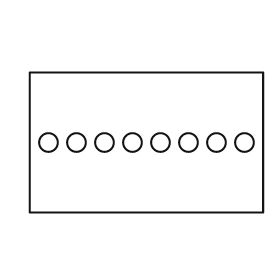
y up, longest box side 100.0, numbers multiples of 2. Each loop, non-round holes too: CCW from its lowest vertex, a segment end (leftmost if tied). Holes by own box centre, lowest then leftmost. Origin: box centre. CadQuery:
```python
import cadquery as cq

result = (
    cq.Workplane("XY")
    .moveTo(-50.0, -30.0)
    .lineTo(50.0, -30.0)
    .lineTo(50.0, 30.0)
    .lineTo(-50.0, 30.0)
    .close()
    .moveTo(-42.0, 0.0)
    .circle(4.0)
    .moveTo(-30.0, 0.0)
    .circle(4.0)
    .moveTo(-18.0, 0.0)
    .circle(4.0)
    .moveTo(-6.0, 0.0)
    .circle(4.0)
    .moveTo(6.0, 0.0)
    .circle(4.0)
    .moveTo(18.0, 0.0)
    .circle(4.0)
    .moveTo(30.0, 0.0)
    .circle(4.0)
    .moveTo(42.0, 0.0)
    .circle(4.0)
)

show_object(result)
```